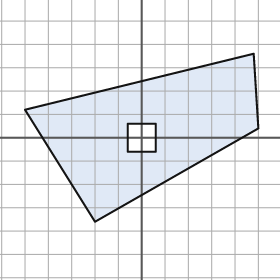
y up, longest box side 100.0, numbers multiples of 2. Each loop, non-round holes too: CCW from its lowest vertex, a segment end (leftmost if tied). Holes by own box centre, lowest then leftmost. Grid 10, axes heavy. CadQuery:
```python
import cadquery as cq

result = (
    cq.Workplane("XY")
    .moveTo(-20.0, -36.0)
    .lineTo(50.0, 4.0)
    .lineTo(48.0, 36.0)
    .lineTo(-50.0, 12.0)
    .close()
    .moveTo(-6.0, -6.0)
    .lineTo(6.0, -6.0)
    .lineTo(6.0, 6.0)
    .lineTo(-6.0, 6.0)
    .close()
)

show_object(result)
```